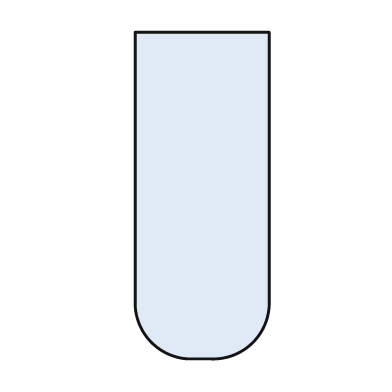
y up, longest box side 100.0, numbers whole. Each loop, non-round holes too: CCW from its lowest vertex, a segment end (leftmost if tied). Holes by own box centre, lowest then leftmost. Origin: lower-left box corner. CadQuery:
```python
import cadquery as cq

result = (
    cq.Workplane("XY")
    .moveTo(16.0, 0.0)
    .lineTo(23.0, 0.0)
    .threePointArc((36.0, 5.0), (41.0, 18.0))
    .lineTo(41.0, 100.0)
    .lineTo(0.0, 100.0)
    .lineTo(0.0, 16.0)
    .threePointArc((5.0, 5.0), (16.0, 0.0))
    .close()
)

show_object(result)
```